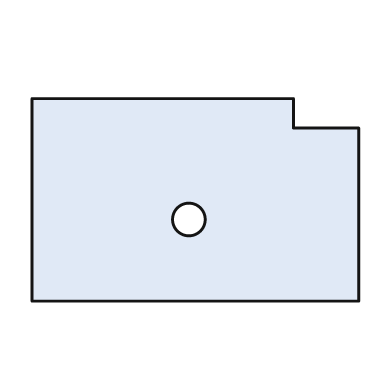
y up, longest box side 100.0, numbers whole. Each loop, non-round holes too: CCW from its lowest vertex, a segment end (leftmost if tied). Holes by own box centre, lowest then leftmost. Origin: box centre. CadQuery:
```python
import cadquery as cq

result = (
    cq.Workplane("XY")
    .moveTo(-50.0, -31.0)
    .lineTo(50.0, -31.0)
    .lineTo(50.0, 22.0)
    .lineTo(30.0, 22.0)
    .lineTo(30.0, 31.0)
    .lineTo(-50.0, 31.0)
    .close()
    .moveTo(-2.0, -6.0)
    .circle(5.0)
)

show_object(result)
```